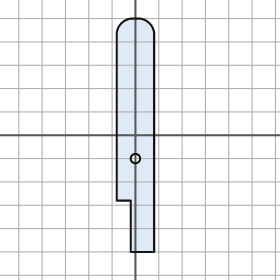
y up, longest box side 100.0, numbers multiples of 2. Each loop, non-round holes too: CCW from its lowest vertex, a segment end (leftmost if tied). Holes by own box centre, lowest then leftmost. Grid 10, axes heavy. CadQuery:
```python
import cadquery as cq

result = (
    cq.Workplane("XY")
    .moveTo(-2.0, -50.0)
    .lineTo(8.0, -50.0)
    .lineTo(8.0, 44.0)
    .threePointArc((6.0, 48.0), (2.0, 50.0))
    .lineTo(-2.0, 50.0)
    .threePointArc((-6.0, 48.0), (-8.0, 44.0))
    .lineTo(-8.0, -28.0)
    .lineTo(-2.0, -28.0)
    .close()
    .moveTo(0.0, -10.0)
    .circle(2.0)
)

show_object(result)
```